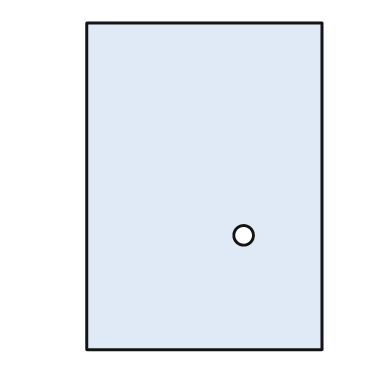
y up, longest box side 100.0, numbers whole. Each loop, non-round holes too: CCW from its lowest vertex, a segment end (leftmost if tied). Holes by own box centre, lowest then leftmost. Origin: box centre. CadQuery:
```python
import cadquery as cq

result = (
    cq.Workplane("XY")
    .moveTo(-36.0, -50.0)
    .lineTo(36.0, -50.0)
    .lineTo(36.0, 50.0)
    .lineTo(-36.0, 50.0)
    .close()
    .moveTo(12.0, -15.0)
    .circle(3.0)
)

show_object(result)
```